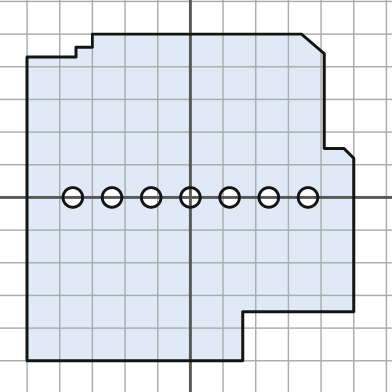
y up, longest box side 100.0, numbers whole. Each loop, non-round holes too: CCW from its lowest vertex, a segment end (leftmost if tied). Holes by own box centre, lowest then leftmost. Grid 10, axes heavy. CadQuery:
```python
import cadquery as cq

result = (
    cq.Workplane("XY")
    .moveTo(-50.0, -50.0)
    .lineTo(16.0, -50.0)
    .lineTo(16.0, -35.0)
    .lineTo(50.0, -35.0)
    .lineTo(50.0, 12.0)
    .lineTo(47.0, 15.0)
    .lineTo(41.0, 15.0)
    .lineTo(41.0, 44.0)
    .lineTo(34.0, 50.0)
    .lineTo(-30.0, 50.0)
    .lineTo(-30.0, 46.0)
    .lineTo(-35.0, 46.0)
    .lineTo(-35.0, 43.0)
    .lineTo(-50.0, 43.0)
    .close()
    .moveTo(-36.0, 0.0)
    .circle(3.0)
    .moveTo(-24.0, 0.0)
    .circle(3.0)
    .moveTo(-12.0, 0.0)
    .circle(3.0)
    .moveTo(0.0, 0.0)
    .circle(3.0)
    .moveTo(12.0, 0.0)
    .circle(3.0)
    .moveTo(24.0, 0.0)
    .circle(3.0)
    .moveTo(36.0, 0.0)
    .circle(3.0)
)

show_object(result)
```